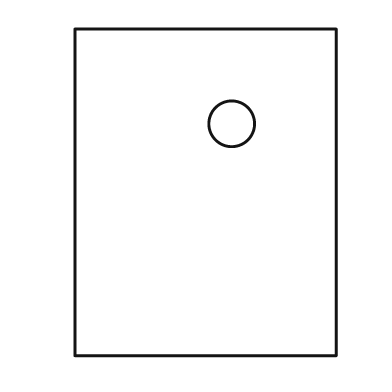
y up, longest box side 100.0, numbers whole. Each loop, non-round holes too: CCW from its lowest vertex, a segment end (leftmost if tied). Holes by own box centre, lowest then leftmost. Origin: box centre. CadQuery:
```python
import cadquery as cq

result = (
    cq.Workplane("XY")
    .moveTo(-40.0, -50.0)
    .lineTo(40.0, -50.0)
    .lineTo(40.0, 50.0)
    .lineTo(-40.0, 50.0)
    .close()
    .moveTo(8.0, 21.0)
    .circle(7.0)
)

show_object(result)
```